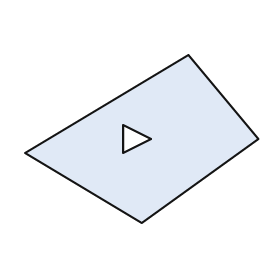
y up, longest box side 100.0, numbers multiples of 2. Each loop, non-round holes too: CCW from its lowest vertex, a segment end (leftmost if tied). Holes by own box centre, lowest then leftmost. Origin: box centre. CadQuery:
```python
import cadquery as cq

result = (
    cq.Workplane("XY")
    .moveTo(0.0, -36.0)
    .lineTo(50.0, 0.0)
    .lineTo(20.0, 36.0)
    .lineTo(-50.0, -6.0)
    .close()
    .moveTo(-8.0, -6.0)
    .lineTo(4.0, 0.0)
    .lineTo(-8.0, 6.0)
    .close()
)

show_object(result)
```